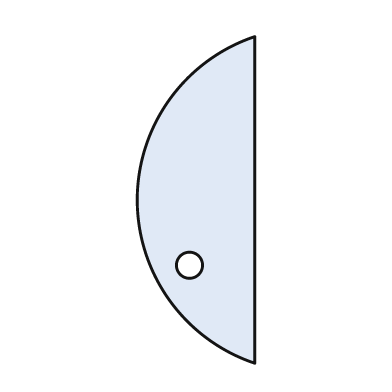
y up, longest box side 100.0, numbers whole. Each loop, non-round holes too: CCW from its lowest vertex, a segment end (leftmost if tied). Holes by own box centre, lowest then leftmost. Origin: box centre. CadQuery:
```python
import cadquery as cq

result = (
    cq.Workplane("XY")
    .moveTo(18.0, -50.0)
    .lineTo(18.0, 50.0)
    .threePointArc((-18.0, 0.0), (18.0, -50.0))
    .close()
    .moveTo(-2.0, -20.0)
    .circle(4.0)
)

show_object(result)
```